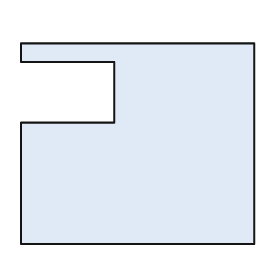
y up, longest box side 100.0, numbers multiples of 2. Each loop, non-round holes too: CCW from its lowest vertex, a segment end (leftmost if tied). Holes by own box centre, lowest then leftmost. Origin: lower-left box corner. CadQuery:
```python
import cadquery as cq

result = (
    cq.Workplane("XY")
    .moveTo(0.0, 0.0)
    .lineTo(100.0, 0.0)
    .lineTo(100.0, 86.0)
    .lineTo(0.0, 86.0)
    .lineTo(0.0, 78.0)
    .lineTo(40.0, 78.0)
    .lineTo(40.0, 52.0)
    .lineTo(0.0, 52.0)
    .close()
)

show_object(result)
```